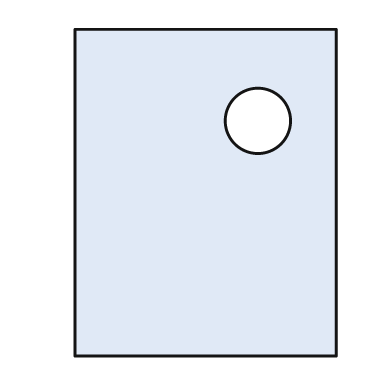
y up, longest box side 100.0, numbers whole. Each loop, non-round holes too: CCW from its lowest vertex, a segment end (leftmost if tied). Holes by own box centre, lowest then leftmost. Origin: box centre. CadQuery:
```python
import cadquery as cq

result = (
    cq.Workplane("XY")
    .moveTo(-40.0, -50.0)
    .lineTo(40.0, -50.0)
    .lineTo(40.0, 50.0)
    .lineTo(-40.0, 50.0)
    .close()
    .moveTo(16.0, 22.0)
    .circle(10.0)
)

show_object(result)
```